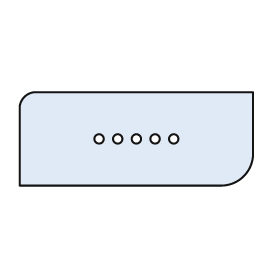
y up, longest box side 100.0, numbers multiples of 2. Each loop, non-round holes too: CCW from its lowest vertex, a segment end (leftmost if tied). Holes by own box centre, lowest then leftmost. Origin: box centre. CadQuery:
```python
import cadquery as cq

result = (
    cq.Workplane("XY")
    .moveTo(-50.0, -20.0)
    .lineTo(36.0, -20.0)
    .threePointArc((46.0, -16.0), (50.0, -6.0))
    .lineTo(50.0, 20.0)
    .lineTo(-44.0, 20.0)
    .threePointArc((-48.0, 18.0), (-50.0, 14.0))
    .close()
    .moveTo(-16.0, 0.0)
    .circle(2.0)
    .moveTo(-8.0, 0.0)
    .circle(2.0)
    .moveTo(0.0, 0.0)
    .circle(2.0)
    .moveTo(8.0, 0.0)
    .circle(2.0)
    .moveTo(16.0, 0.0)
    .circle(2.0)
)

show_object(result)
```